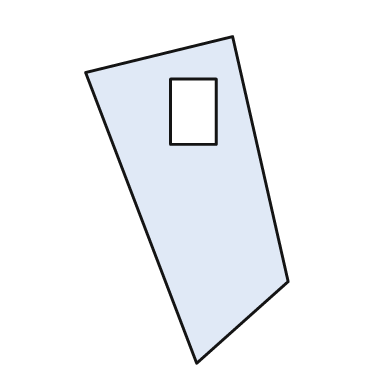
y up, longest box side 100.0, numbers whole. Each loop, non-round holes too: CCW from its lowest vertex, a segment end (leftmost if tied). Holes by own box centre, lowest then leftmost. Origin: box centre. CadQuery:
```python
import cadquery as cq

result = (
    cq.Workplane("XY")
    .moveTo(3.0, -50.0)
    .lineTo(31.0, -25.0)
    .lineTo(14.0, 50.0)
    .lineTo(-31.0, 39.0)
    .close()
    .moveTo(-5.0, 17.0)
    .lineTo(9.0, 17.0)
    .lineTo(9.0, 37.0)
    .lineTo(-5.0, 37.0)
    .close()
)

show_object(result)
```